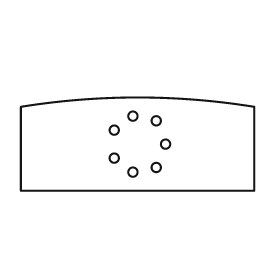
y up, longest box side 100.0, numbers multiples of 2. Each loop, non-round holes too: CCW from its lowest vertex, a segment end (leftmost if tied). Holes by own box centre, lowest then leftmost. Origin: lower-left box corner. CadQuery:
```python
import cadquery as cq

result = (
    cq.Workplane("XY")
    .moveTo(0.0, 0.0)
    .lineTo(100.0, 0.0)
    .lineTo(100.0, 36.0)
    .threePointArc((50.0, 40.0), (0.0, 36.0))
    .close()
    .moveTo(48.0, 8.0)
    .circle(2.0)
    .moveTo(58.0, 10.0)
    .circle(2.0)
    .moveTo(40.0, 14.0)
    .circle(2.0)
    .moveTo(62.0, 20.0)
    .circle(2.0)
    .moveTo(40.0, 26.0)
    .circle(2.0)
    .moveTo(58.0, 30.0)
    .circle(2.0)
    .moveTo(48.0, 32.0)
    .circle(2.0)
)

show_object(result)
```